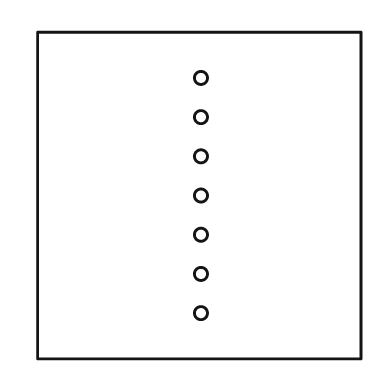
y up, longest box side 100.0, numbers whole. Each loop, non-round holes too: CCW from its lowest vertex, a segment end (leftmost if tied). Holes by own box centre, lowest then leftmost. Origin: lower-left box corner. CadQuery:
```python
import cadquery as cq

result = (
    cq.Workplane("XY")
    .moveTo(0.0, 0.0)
    .lineTo(99.0, 0.0)
    .lineTo(99.0, 100.0)
    .lineTo(0.0, 100.0)
    .close()
    .moveTo(50.0, 14.0)
    .circle(2.0)
    .moveTo(50.0, 26.0)
    .circle(2.0)
    .moveTo(50.0, 38.0)
    .circle(2.0)
    .moveTo(50.0, 50.0)
    .circle(2.0)
    .moveTo(50.0, 62.0)
    .circle(2.0)
    .moveTo(50.0, 74.0)
    .circle(2.0)
    .moveTo(50.0, 86.0)
    .circle(2.0)
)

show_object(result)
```